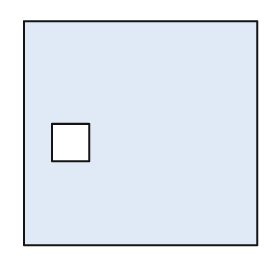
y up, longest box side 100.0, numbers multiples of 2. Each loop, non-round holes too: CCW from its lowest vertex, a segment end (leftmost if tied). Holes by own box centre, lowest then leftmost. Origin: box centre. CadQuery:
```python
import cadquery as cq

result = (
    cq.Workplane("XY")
    .moveTo(-50.0, -48.0)
    .lineTo(50.0, -48.0)
    .lineTo(50.0, 48.0)
    .lineTo(-50.0, 48.0)
    .close()
    .moveTo(-38.0, -12.0)
    .lineTo(-22.0, -12.0)
    .lineTo(-22.0, 4.0)
    .lineTo(-38.0, 4.0)
    .close()
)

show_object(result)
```